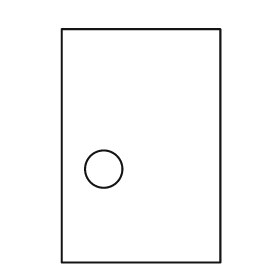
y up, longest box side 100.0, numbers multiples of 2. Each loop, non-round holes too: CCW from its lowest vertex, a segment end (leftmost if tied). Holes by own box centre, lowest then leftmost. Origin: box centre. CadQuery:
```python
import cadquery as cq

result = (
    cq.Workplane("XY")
    .moveTo(-34.0, -50.0)
    .lineTo(34.0, -50.0)
    .lineTo(34.0, 50.0)
    .lineTo(-34.0, 50.0)
    .close()
    .moveTo(-16.0, -10.0)
    .circle(8.0)
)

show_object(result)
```